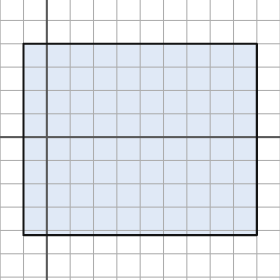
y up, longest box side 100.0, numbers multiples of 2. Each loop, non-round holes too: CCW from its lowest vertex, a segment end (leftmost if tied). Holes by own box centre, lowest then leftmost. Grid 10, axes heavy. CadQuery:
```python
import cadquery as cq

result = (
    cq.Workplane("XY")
    .moveTo(-10.0, -42.0)
    .lineTo(90.0, -42.0)
    .lineTo(90.0, 40.0)
    .lineTo(-10.0, 40.0)
    .close()
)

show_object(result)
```